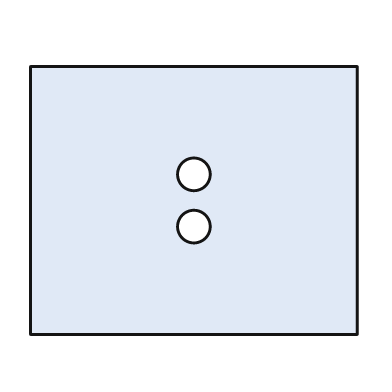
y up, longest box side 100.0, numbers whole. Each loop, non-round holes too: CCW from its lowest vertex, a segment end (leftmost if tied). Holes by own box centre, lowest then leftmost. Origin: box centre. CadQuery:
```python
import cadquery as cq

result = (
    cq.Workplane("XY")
    .moveTo(-50.0, -41.0)
    .lineTo(50.0, -41.0)
    .lineTo(50.0, 41.0)
    .lineTo(-50.0, 41.0)
    .close()
    .moveTo(0.0, -8.0)
    .circle(5.0)
    .moveTo(0.0, 8.0)
    .circle(5.0)
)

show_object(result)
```